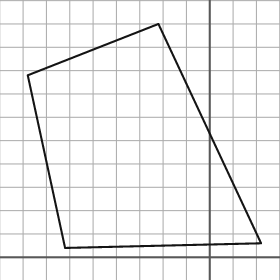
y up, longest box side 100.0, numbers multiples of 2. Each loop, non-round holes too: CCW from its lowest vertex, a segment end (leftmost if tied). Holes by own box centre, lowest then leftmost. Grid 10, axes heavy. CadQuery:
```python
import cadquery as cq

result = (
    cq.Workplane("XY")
    .moveTo(-62.0, 4.0)
    .lineTo(22.0, 6.0)
    .lineTo(-22.0, 100.0)
    .lineTo(-78.0, 78.0)
    .close()
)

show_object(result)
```